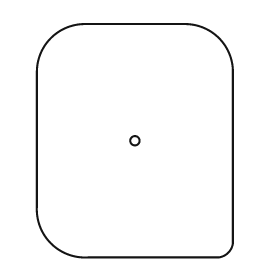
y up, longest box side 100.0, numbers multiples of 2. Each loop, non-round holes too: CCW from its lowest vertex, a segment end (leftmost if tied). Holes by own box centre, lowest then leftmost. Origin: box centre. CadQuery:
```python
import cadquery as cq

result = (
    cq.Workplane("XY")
    .moveTo(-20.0, -50.0)
    .lineTo(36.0, -50.0)
    .threePointArc((40.0, -48.0), (42.0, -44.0))
    .lineTo(42.0, 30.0)
    .threePointArc((36.0, 44.0), (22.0, 50.0))
    .lineTo(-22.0, 50.0)
    .threePointArc((-36.0, 44.0), (-42.0, 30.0))
    .lineTo(-42.0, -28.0)
    .threePointArc((-36.0, -44.0), (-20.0, -50.0))
    .close()
    .moveTo(0.0, 0.0)
    .circle(2.0)
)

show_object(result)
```